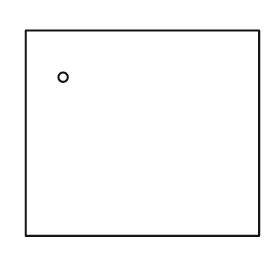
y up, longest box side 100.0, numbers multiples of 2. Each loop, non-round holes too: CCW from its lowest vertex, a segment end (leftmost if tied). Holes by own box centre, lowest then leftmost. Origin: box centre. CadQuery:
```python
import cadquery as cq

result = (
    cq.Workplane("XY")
    .moveTo(-50.0, -44.0)
    .lineTo(50.0, -44.0)
    .lineTo(50.0, 44.0)
    .lineTo(-50.0, 44.0)
    .close()
    .moveTo(-34.0, 24.0)
    .circle(2.0)
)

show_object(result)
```